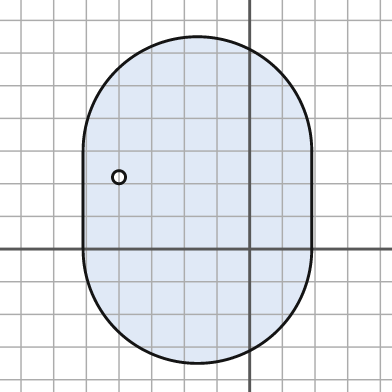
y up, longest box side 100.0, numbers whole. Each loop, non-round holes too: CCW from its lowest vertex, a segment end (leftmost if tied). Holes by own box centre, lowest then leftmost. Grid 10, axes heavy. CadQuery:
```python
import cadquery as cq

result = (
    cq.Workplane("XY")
    .moveTo(-51.0, 0.0)
    .threePointArc((-16.0, -35.0), (19.0, 0.0))
    .lineTo(19.0, 30.0)
    .threePointArc((-16.0, 65.0), (-51.0, 30.0))
    .close()
    .moveTo(-40.0, 22.0)
    .circle(2.0)
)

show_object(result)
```